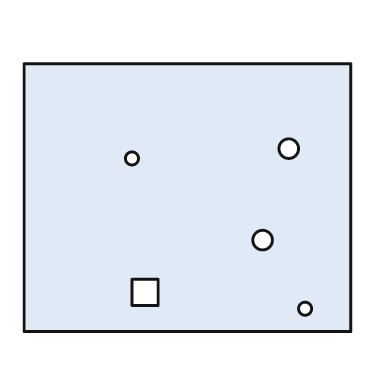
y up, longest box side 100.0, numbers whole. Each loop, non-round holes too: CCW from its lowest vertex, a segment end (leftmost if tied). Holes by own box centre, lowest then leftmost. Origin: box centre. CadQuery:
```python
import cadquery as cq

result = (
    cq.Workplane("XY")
    .moveTo(-50.0, -41.0)
    .lineTo(50.0, -41.0)
    .lineTo(50.0, 41.0)
    .lineTo(-50.0, 41.0)
    .close()
    .moveTo(36.0, -34.0)
    .circle(2.0)
    .moveTo(-17.0, -33.0)
    .lineTo(-9.0, -33.0)
    .lineTo(-9.0, -25.0)
    .lineTo(-17.0, -25.0)
    .close()
    .moveTo(23.0, -13.0)
    .circle(3.0)
    .moveTo(-17.0, 12.0)
    .circle(2.0)
    .moveTo(31.0, 15.0)
    .circle(3.0)
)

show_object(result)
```